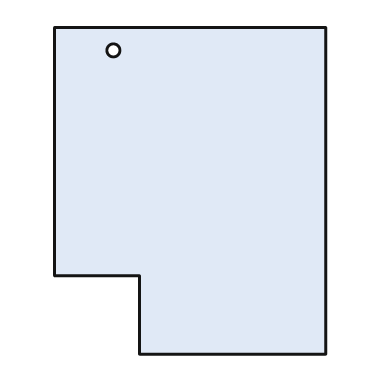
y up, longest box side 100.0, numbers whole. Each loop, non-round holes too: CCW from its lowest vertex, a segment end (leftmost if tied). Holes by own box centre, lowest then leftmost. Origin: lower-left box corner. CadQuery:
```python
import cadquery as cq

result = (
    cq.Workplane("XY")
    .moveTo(26.0, 0.0)
    .lineTo(83.0, 0.0)
    .lineTo(83.0, 100.0)
    .lineTo(0.0, 100.0)
    .lineTo(0.0, 24.0)
    .lineTo(26.0, 24.0)
    .close()
    .moveTo(18.0, 93.0)
    .circle(2.0)
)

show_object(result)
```